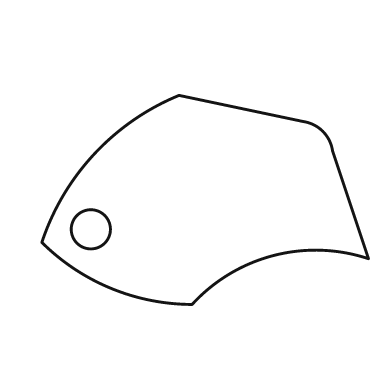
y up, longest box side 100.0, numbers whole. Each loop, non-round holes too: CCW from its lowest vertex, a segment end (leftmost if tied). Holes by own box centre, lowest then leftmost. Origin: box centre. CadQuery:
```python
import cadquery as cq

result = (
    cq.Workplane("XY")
    .moveTo(-4.0, -32.0)
    .threePointArc((21.0, -17.0), (50.0, -18.0))
    .lineTo(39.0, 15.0)
    .threePointArc((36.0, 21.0), (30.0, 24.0))
    .lineTo(-8.0, 32.0)
    .threePointArc((-34.0, 14.0), (-50.0, -13.0))
    .threePointArc((-29.0, -27.0), (-4.0, -32.0))
    .close()
    .moveTo(-35.0, -9.0)
    .circle(6.0)
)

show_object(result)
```